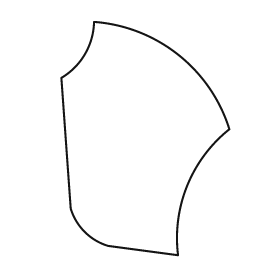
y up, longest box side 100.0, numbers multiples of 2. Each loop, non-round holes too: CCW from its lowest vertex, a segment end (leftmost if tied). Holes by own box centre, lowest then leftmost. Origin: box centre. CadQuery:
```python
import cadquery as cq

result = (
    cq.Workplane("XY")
    .moveTo(14.0, -50.0)
    .threePointArc((18.0, -20.0), (36.0, 4.0))
    .threePointArc((14.0, 36.0), (-22.0, 50.0))
    .threePointArc((-26.0, 36.0), (-36.0, 26.0))
    .lineTo(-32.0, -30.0)
    .threePointArc((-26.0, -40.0), (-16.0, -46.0))
    .close()
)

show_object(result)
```